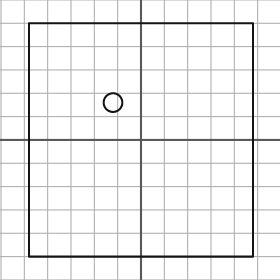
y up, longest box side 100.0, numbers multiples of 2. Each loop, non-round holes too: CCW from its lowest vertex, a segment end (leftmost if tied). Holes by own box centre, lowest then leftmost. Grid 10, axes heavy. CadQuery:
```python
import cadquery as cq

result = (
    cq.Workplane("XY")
    .moveTo(-48.0, -50.0)
    .lineTo(48.0, -50.0)
    .lineTo(48.0, 50.0)
    .lineTo(-48.0, 50.0)
    .close()
    .moveTo(-12.0, 16.0)
    .circle(4.0)
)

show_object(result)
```